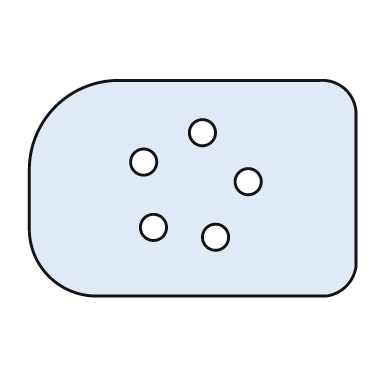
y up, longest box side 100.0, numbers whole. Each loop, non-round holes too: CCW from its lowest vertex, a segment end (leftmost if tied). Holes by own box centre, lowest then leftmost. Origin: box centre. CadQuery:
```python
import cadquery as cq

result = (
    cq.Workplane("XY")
    .moveTo(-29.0, -33.0)
    .lineTo(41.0, -33.0)
    .threePointArc((47.0, -30.0), (50.0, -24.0))
    .lineTo(50.0, 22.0)
    .threePointArc((47.0, 30.0), (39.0, 33.0))
    .lineTo(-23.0, 33.0)
    .threePointArc((-42.0, 25.0), (-50.0, 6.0))
    .lineTo(-50.0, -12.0)
    .threePointArc((-44.0, -27.0), (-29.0, -33.0))
    .close()
    .moveTo(7.0, -15.0)
    .circle(4.0)
    .moveTo(-12.0, -12.0)
    .circle(4.0)
    .moveTo(17.0, 2.0)
    .circle(4.0)
    .moveTo(-15.0, 8.0)
    .circle(4.0)
    .moveTo(3.0, 17.0)
    .circle(4.0)
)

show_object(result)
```